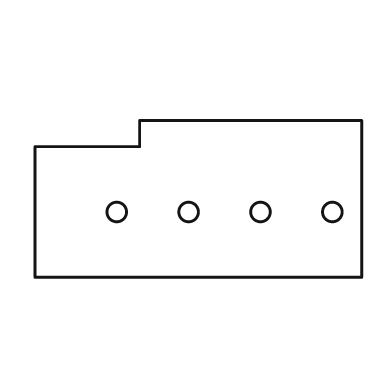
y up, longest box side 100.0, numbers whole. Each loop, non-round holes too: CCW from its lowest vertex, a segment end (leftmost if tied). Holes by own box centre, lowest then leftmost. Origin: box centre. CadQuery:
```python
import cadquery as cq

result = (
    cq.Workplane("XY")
    .moveTo(-50.0, -24.0)
    .lineTo(50.0, -24.0)
    .lineTo(50.0, 24.0)
    .lineTo(-18.0, 24.0)
    .lineTo(-18.0, 16.0)
    .lineTo(-50.0, 16.0)
    .close()
    .moveTo(-25.0, -4.0)
    .circle(3.0)
    .moveTo(-3.0, -4.0)
    .circle(3.0)
    .moveTo(19.0, -4.0)
    .circle(3.0)
    .moveTo(41.0, -4.0)
    .circle(3.0)
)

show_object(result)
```